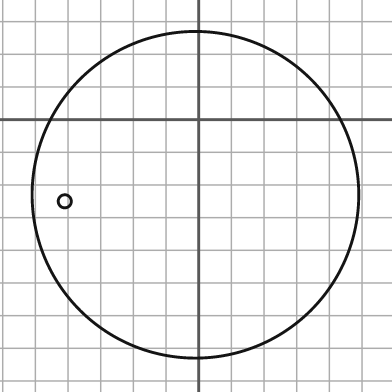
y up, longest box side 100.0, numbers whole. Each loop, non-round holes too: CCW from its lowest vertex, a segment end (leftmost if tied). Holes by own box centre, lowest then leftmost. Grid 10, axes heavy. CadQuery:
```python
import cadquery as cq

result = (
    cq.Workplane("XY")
    .moveTo(-1.0, -23.0)
    .circle(50.0)
    .moveTo(-41.0, -25.0)
    .circle(2.0)
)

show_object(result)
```